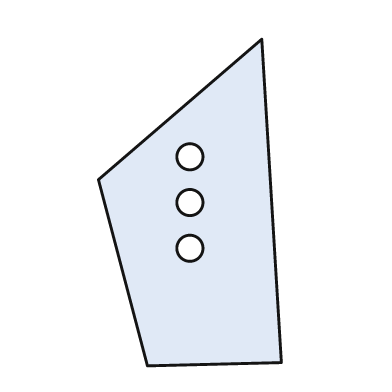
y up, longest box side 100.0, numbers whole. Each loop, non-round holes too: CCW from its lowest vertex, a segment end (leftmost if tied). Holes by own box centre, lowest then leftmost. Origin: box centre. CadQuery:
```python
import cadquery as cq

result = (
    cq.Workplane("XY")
    .moveTo(-13.0, -50.0)
    .lineTo(28.0, -49.0)
    .lineTo(22.0, 50.0)
    .lineTo(-28.0, 7.0)
    .close()
    .moveTo(0.0, -14.0)
    .circle(4.0)
    .moveTo(0.0, 0.0)
    .circle(4.0)
    .moveTo(0.0, 14.0)
    .circle(4.0)
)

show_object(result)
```